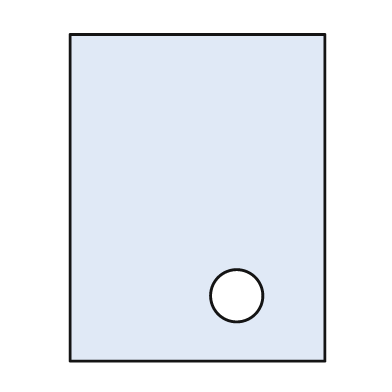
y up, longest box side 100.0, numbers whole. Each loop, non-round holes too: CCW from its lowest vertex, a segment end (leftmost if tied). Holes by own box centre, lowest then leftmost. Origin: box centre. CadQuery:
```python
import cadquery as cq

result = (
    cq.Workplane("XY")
    .moveTo(-39.0, -50.0)
    .lineTo(39.0, -50.0)
    .lineTo(39.0, 50.0)
    .lineTo(-39.0, 50.0)
    .close()
    .moveTo(12.0, -30.0)
    .circle(8.0)
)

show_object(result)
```